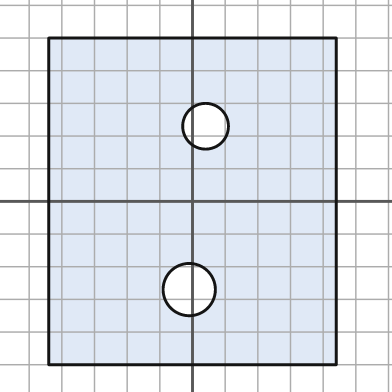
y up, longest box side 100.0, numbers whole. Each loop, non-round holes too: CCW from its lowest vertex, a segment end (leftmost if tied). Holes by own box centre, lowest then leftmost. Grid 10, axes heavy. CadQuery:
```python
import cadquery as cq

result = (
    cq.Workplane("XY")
    .moveTo(-44.0, -50.0)
    .lineTo(44.0, -50.0)
    .lineTo(44.0, 50.0)
    .lineTo(-44.0, 50.0)
    .close()
    .moveTo(-1.0, -27.0)
    .circle(8.0)
    .moveTo(4.0, 23.0)
    .circle(7.0)
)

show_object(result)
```